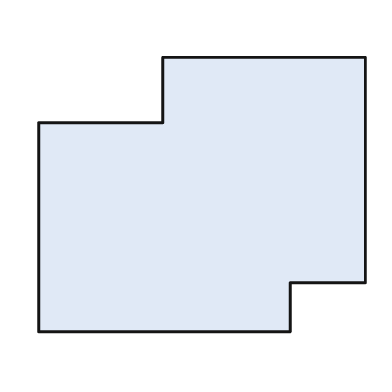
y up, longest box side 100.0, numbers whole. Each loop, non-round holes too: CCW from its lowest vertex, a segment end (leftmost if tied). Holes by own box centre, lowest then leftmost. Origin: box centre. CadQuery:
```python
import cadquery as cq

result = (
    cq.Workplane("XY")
    .moveTo(-50.0, -42.0)
    .lineTo(27.0, -42.0)
    .lineTo(27.0, -27.0)
    .lineTo(50.0, -27.0)
    .lineTo(50.0, 42.0)
    .lineTo(-12.0, 42.0)
    .lineTo(-12.0, 22.0)
    .lineTo(-50.0, 22.0)
    .close()
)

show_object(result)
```